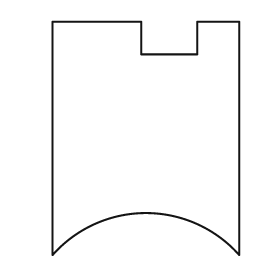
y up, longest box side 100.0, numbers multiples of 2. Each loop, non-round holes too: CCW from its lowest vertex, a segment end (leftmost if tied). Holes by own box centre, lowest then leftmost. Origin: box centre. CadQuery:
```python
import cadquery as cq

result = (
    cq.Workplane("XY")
    .moveTo(-40.0, -50.0)
    .threePointArc((0.0, -32.0), (40.0, -50.0))
    .lineTo(40.0, 50.0)
    .lineTo(22.0, 50.0)
    .lineTo(22.0, 36.0)
    .lineTo(-2.0, 36.0)
    .lineTo(-2.0, 50.0)
    .lineTo(-40.0, 50.0)
    .close()
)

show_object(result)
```